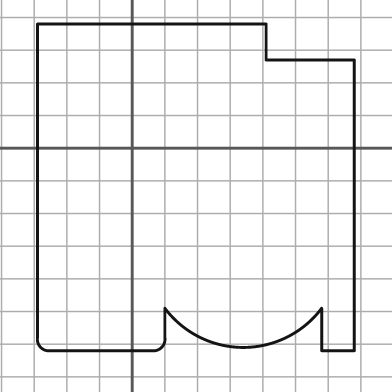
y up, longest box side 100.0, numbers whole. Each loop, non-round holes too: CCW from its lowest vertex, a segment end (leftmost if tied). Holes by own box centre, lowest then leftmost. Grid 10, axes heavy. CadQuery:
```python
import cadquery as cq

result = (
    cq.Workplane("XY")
    .moveTo(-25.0, -62.0)
    .lineTo(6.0, -62.0)
    .threePointArc((9.0, -61.0), (10.0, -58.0))
    .lineTo(10.0, -49.0)
    .threePointArc((34.0, -61.0), (58.0, -49.0))
    .lineTo(58.0, -62.0)
    .lineTo(68.0, -62.0)
    .lineTo(68.0, 27.0)
    .lineTo(41.0, 27.0)
    .lineTo(41.0, 38.0)
    .lineTo(-29.0, 38.0)
    .lineTo(-29.0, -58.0)
    .threePointArc((-28.0, -61.0), (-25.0, -62.0))
    .close()
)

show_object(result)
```